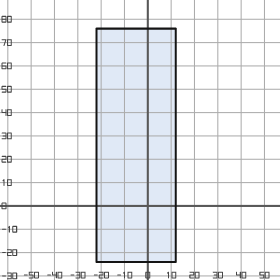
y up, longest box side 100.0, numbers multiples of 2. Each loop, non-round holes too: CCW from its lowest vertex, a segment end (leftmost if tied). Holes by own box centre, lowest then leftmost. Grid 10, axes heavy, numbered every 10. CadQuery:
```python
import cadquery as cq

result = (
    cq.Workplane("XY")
    .moveTo(-22.0, -24.0)
    .lineTo(12.0, -24.0)
    .lineTo(12.0, 76.0)
    .lineTo(-22.0, 76.0)
    .close()
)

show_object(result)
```